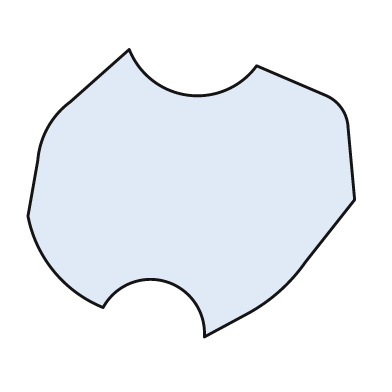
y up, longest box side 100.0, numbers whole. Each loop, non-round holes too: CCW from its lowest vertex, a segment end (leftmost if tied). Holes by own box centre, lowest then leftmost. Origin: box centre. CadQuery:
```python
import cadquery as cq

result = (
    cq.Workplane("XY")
    .moveTo(4.0, -44.0)
    .lineTo(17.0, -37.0)
    .threePointArc((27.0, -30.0), (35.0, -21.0))
    .lineTo(50.0, -2.0)
    .lineTo(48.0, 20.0)
    .threePointArc((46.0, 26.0), (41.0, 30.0))
    .lineTo(20.0, 39.0)
    .threePointArc((-1.0, 30.0), (-19.0, 44.0))
    .lineTo(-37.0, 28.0)
    .threePointArc((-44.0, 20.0), (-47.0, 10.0))
    .lineTo(-50.0, -7.0)
    .threePointArc((-42.0, -24.0), (-27.0, -35.0))
    .threePointArc((-8.0, -27.0), (4.0, -44.0))
    .close()
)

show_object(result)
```